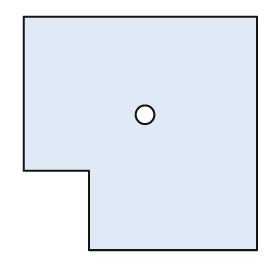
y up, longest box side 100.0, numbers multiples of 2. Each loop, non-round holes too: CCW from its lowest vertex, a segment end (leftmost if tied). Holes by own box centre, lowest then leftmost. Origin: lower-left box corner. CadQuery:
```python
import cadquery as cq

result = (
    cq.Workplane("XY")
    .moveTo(28.0, 0.0)
    .lineTo(100.0, 0.0)
    .lineTo(100.0, 100.0)
    .lineTo(0.0, 100.0)
    .lineTo(0.0, 34.0)
    .lineTo(28.0, 34.0)
    .close()
    .moveTo(52.0, 58.0)
    .circle(4.0)
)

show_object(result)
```